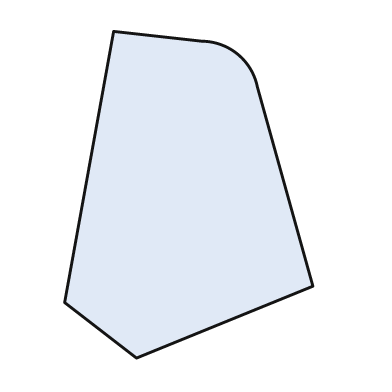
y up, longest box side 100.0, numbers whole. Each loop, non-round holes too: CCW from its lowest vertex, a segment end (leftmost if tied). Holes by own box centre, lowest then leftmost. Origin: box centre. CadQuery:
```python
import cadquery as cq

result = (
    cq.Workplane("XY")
    .moveTo(-16.0, -50.0)
    .lineTo(38.0, -28.0)
    .lineTo(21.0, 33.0)
    .threePointArc((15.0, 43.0), (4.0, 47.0))
    .lineTo(-23.0, 50.0)
    .lineTo(-38.0, -33.0)
    .close()
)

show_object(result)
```